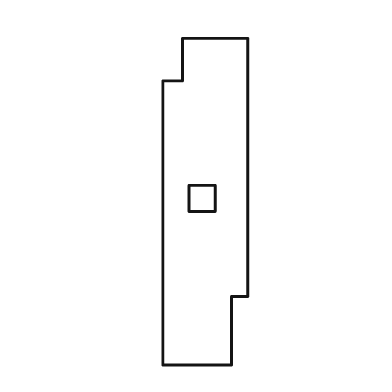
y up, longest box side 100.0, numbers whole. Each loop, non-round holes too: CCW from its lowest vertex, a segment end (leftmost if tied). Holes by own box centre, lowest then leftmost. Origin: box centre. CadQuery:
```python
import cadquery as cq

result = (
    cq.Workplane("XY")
    .moveTo(-13.0, -50.0)
    .lineTo(8.0, -50.0)
    .lineTo(8.0, -29.0)
    .lineTo(13.0, -29.0)
    .lineTo(13.0, 50.0)
    .lineTo(-7.0, 50.0)
    .lineTo(-7.0, 37.0)
    .lineTo(-13.0, 37.0)
    .close()
    .moveTo(-5.0, -3.0)
    .lineTo(3.0, -3.0)
    .lineTo(3.0, 5.0)
    .lineTo(-5.0, 5.0)
    .close()
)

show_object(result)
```